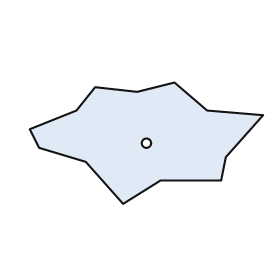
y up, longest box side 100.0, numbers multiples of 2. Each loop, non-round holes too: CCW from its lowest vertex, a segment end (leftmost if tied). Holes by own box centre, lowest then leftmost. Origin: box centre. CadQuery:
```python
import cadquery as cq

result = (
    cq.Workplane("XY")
    .moveTo(-10.0, -26.0)
    .lineTo(6.0, -16.0)
    .lineTo(32.0, -16.0)
    .lineTo(34.0, -6.0)
    .lineTo(50.0, 12.0)
    .lineTo(26.0, 14.0)
    .lineTo(12.0, 26.0)
    .lineTo(-4.0, 22.0)
    .lineTo(-22.0, 24.0)
    .lineTo(-30.0, 14.0)
    .lineTo(-50.0, 6.0)
    .lineTo(-46.0, -2.0)
    .lineTo(-26.0, -8.0)
    .close()
    .moveTo(0.0, 0.0)
    .circle(2.0)
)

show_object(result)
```